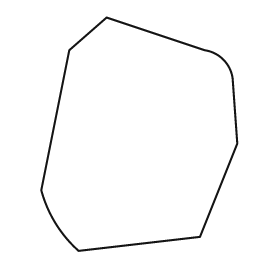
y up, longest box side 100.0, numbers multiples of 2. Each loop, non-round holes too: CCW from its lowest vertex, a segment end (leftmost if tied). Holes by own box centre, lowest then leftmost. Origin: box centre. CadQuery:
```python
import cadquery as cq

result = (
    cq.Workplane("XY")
    .moveTo(-26.0, -50.0)
    .lineTo(26.0, -44.0)
    .lineTo(42.0, -4.0)
    .lineTo(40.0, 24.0)
    .threePointArc((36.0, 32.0), (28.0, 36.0))
    .lineTo(-14.0, 50.0)
    .lineTo(-30.0, 36.0)
    .lineTo(-42.0, -24.0)
    .threePointArc((-36.0, -38.0), (-26.0, -50.0))
    .close()
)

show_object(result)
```